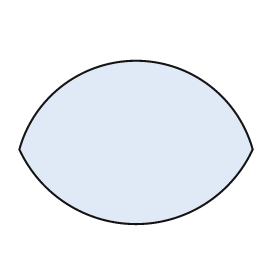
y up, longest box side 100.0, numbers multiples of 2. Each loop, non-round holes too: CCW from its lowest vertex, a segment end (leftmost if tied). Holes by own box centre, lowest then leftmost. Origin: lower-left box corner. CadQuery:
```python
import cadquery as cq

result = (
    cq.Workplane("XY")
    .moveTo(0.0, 32.0)
    .threePointArc((50.0, 0.0), (100.0, 32.0))
    .threePointArc((50.0, 70.0), (0.0, 32.0))
    .close()
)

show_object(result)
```